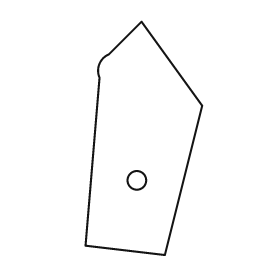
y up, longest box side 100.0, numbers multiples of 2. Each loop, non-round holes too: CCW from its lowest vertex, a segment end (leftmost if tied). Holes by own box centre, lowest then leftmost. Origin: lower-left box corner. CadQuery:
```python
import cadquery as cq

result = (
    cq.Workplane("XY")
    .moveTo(34.0, 0.0)
    .lineTo(50.0, 64.0)
    .lineTo(24.0, 100.0)
    .lineTo(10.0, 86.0)
    .threePointArc((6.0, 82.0), (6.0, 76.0))
    .lineTo(0.0, 4.0)
    .close()
    .moveTo(22.0, 32.0)
    .circle(4.0)
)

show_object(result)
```